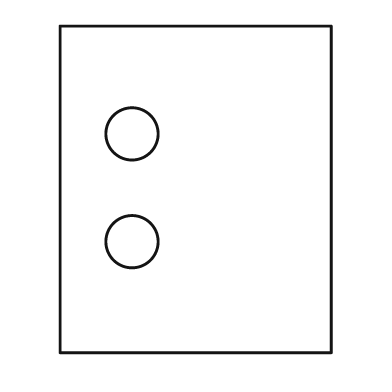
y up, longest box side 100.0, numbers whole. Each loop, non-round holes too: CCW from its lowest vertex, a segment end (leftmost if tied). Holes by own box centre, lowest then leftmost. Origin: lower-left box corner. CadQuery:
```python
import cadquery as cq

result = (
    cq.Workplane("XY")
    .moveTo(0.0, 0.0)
    .lineTo(83.0, 0.0)
    .lineTo(83.0, 100.0)
    .lineTo(0.0, 100.0)
    .close()
    .moveTo(22.0, 34.0)
    .circle(8.0)
    .moveTo(22.0, 67.0)
    .circle(8.0)
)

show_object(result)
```